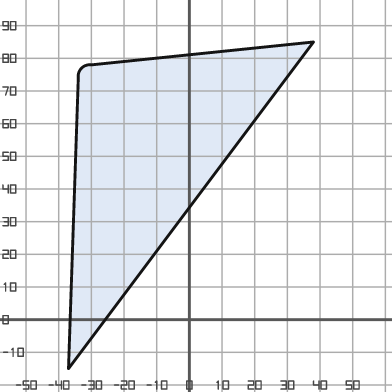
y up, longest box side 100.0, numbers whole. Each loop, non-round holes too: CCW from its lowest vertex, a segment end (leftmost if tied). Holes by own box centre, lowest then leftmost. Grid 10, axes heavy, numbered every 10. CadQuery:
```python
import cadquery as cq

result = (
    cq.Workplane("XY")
    .moveTo(-37.0, -15.0)
    .lineTo(38.0, 85.0)
    .lineTo(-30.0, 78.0)
    .threePointArc((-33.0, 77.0), (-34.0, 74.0))
    .close()
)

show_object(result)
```